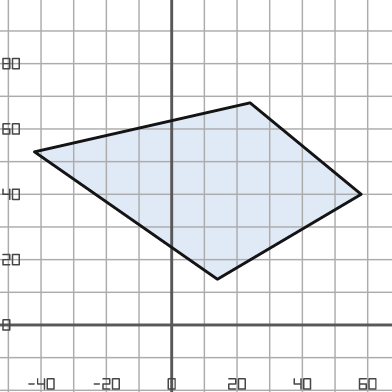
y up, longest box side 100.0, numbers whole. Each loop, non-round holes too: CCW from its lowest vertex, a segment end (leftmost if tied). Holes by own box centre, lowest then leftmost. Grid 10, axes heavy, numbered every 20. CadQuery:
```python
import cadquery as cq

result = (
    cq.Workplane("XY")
    .moveTo(14.0, 14.0)
    .lineTo(58.0, 40.0)
    .lineTo(24.0, 68.0)
    .lineTo(-42.0, 53.0)
    .close()
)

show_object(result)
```